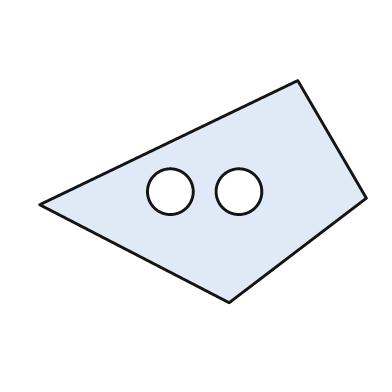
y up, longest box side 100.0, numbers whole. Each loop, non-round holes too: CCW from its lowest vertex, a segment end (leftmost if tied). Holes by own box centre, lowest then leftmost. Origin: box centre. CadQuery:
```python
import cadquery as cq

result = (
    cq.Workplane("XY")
    .moveTo(8.0, -34.0)
    .lineTo(50.0, -2.0)
    .lineTo(29.0, 34.0)
    .lineTo(-50.0, -4.0)
    .close()
    .moveTo(-10.0, 0.0)
    .circle(7.0)
    .moveTo(11.0, 0.0)
    .circle(7.0)
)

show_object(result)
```